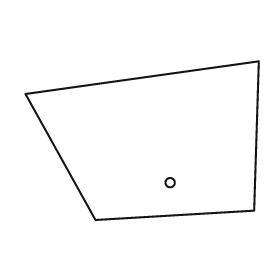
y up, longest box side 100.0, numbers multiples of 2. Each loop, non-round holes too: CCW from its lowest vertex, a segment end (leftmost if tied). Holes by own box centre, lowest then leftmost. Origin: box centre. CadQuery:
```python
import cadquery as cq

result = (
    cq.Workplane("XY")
    .moveTo(-20.0, -34.0)
    .lineTo(48.0, -30.0)
    .lineTo(50.0, 34.0)
    .lineTo(-50.0, 20.0)
    .close()
    .moveTo(12.0, -18.0)
    .circle(2.0)
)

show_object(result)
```